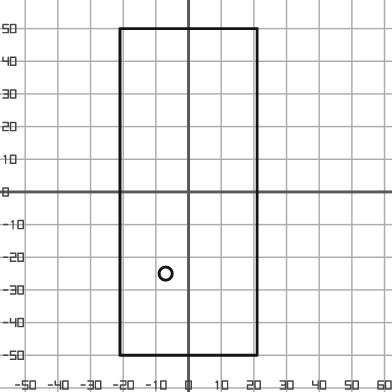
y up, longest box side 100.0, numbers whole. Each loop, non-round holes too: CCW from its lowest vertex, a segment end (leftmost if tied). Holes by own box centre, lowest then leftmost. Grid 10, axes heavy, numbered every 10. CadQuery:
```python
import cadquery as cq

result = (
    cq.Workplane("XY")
    .moveTo(-21.0, -50.0)
    .lineTo(21.0, -50.0)
    .lineTo(21.0, 50.0)
    .lineTo(-21.0, 50.0)
    .close()
    .moveTo(-7.0, -25.0)
    .circle(2.0)
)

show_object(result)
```